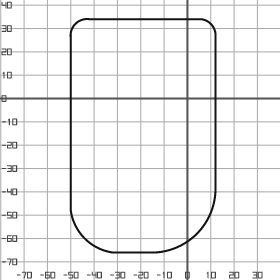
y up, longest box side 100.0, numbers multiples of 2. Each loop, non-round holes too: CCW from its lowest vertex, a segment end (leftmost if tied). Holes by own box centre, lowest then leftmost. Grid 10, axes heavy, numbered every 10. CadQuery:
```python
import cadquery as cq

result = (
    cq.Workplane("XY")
    .moveTo(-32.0, -66.0)
    .lineTo(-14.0, -66.0)
    .threePointArc((4.0, -58.0), (12.0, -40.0))
    .lineTo(12.0, 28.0)
    .threePointArc((10.0, 32.0), (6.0, 34.0))
    .lineTo(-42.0, 34.0)
    .threePointArc((-48.0, 32.0), (-50.0, 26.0))
    .lineTo(-50.0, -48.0)
    .threePointArc((-44.0, -60.0), (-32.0, -66.0))
    .close()
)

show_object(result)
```